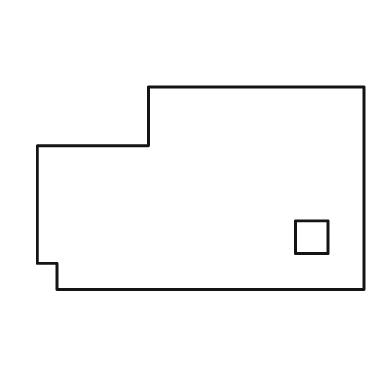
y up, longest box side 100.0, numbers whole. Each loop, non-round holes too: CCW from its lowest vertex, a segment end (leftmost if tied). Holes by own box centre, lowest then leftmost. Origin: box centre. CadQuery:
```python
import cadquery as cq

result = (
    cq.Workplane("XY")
    .moveTo(-44.0, -31.0)
    .lineTo(50.0, -31.0)
    .lineTo(50.0, 31.0)
    .lineTo(-16.0, 31.0)
    .lineTo(-16.0, 13.0)
    .lineTo(-50.0, 13.0)
    .lineTo(-50.0, -23.0)
    .lineTo(-44.0, -23.0)
    .close()
    .moveTo(29.0, -20.0)
    .lineTo(39.0, -20.0)
    .lineTo(39.0, -10.0)
    .lineTo(29.0, -10.0)
    .close()
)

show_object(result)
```